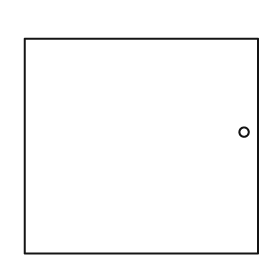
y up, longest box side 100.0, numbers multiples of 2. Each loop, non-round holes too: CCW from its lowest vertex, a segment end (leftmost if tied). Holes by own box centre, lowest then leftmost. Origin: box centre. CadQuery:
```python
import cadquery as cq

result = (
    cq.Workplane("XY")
    .moveTo(-50.0, -46.0)
    .lineTo(50.0, -46.0)
    .lineTo(50.0, 46.0)
    .lineTo(-50.0, 46.0)
    .close()
    .moveTo(44.0, 6.0)
    .circle(2.0)
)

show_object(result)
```